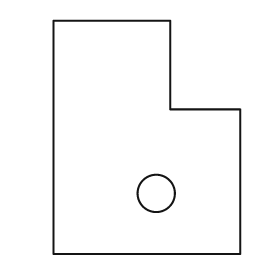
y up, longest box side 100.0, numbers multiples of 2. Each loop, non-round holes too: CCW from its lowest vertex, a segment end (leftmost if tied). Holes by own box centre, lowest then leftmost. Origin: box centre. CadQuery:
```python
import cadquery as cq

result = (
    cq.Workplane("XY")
    .moveTo(-40.0, -50.0)
    .lineTo(40.0, -50.0)
    .lineTo(40.0, 12.0)
    .lineTo(10.0, 12.0)
    .lineTo(10.0, 50.0)
    .lineTo(-40.0, 50.0)
    .close()
    .moveTo(4.0, -24.0)
    .circle(8.0)
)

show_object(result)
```